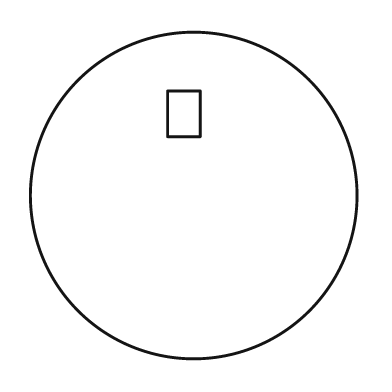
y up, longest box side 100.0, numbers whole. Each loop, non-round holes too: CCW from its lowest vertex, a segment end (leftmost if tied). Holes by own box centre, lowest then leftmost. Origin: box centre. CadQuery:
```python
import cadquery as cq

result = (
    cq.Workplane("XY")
    .moveTo(0.0, 0.0)
    .circle(50.0)
    .moveTo(-8.0, 18.0)
    .lineTo(2.0, 18.0)
    .lineTo(2.0, 32.0)
    .lineTo(-8.0, 32.0)
    .close()
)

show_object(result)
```